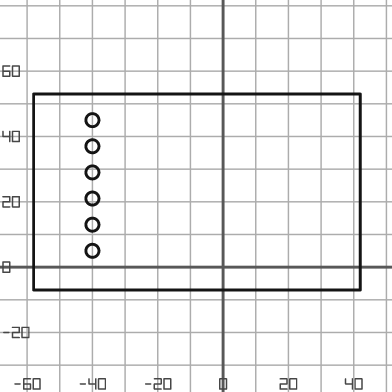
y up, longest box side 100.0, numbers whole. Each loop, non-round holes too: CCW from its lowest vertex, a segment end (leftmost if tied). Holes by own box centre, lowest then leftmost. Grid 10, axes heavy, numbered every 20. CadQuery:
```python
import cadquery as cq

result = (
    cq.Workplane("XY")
    .moveTo(-58.0, -7.0)
    .lineTo(42.0, -7.0)
    .lineTo(42.0, 53.0)
    .lineTo(-58.0, 53.0)
    .close()
    .moveTo(-40.0, 5.0)
    .circle(2.0)
    .moveTo(-40.0, 13.0)
    .circle(2.0)
    .moveTo(-40.0, 21.0)
    .circle(2.0)
    .moveTo(-40.0, 29.0)
    .circle(2.0)
    .moveTo(-40.0, 37.0)
    .circle(2.0)
    .moveTo(-40.0, 45.0)
    .circle(2.0)
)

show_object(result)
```